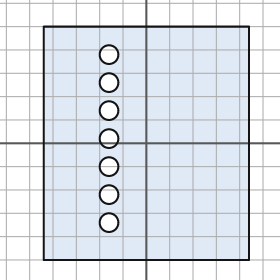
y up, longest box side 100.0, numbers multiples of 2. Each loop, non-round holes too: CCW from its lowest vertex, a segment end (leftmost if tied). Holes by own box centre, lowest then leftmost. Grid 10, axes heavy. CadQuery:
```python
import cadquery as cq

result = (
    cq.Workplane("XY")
    .moveTo(-44.0, -50.0)
    .lineTo(44.0, -50.0)
    .lineTo(44.0, 50.0)
    .lineTo(-44.0, 50.0)
    .close()
    .moveTo(-16.0, -34.0)
    .circle(4.0)
    .moveTo(-16.0, -22.0)
    .circle(4.0)
    .moveTo(-16.0, -10.0)
    .circle(4.0)
    .moveTo(-16.0, 2.0)
    .circle(4.0)
    .moveTo(-16.0, 14.0)
    .circle(4.0)
    .moveTo(-16.0, 26.0)
    .circle(4.0)
    .moveTo(-16.0, 38.0)
    .circle(4.0)
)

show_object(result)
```